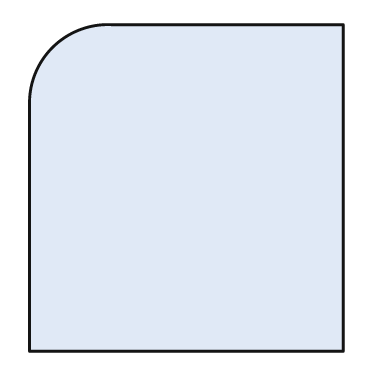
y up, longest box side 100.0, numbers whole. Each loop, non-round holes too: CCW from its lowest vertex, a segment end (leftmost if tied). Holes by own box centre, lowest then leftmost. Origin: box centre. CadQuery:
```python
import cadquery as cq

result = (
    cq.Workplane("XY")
    .moveTo(-48.0, -50.0)
    .lineTo(48.0, -50.0)
    .lineTo(48.0, 50.0)
    .lineTo(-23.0, 50.0)
    .threePointArc((-41.0, 43.0), (-48.0, 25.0))
    .close()
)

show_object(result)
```